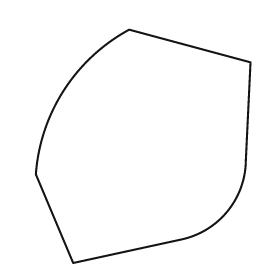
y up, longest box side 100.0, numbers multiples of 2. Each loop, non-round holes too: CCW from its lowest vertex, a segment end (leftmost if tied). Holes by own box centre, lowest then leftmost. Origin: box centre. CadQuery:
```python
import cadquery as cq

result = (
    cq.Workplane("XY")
    .moveTo(-30.0, -50.0)
    .lineTo(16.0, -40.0)
    .threePointArc((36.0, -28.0), (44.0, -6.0))
    .lineTo(46.0, 36.0)
    .lineTo(-6.0, 50.0)
    .threePointArc((-34.0, 24.0), (-46.0, -12.0))
    .close()
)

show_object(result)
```